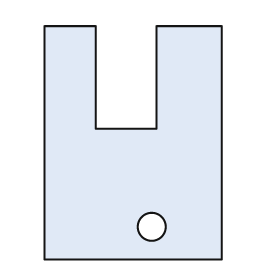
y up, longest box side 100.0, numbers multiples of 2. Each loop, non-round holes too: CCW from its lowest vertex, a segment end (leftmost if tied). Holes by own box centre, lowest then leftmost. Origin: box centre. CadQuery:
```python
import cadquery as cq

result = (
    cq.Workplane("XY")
    .moveTo(-38.0, -50.0)
    .lineTo(38.0, -50.0)
    .lineTo(38.0, 50.0)
    .lineTo(10.0, 50.0)
    .lineTo(10.0, 6.0)
    .lineTo(-16.0, 6.0)
    .lineTo(-16.0, 50.0)
    .lineTo(-38.0, 50.0)
    .close()
    .moveTo(8.0, -36.0)
    .circle(6.0)
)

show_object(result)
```